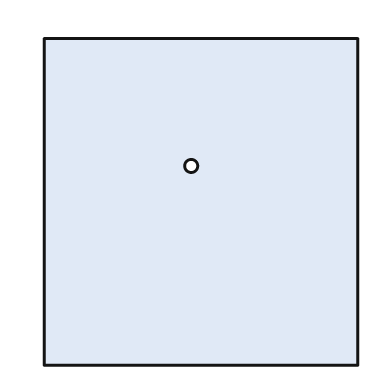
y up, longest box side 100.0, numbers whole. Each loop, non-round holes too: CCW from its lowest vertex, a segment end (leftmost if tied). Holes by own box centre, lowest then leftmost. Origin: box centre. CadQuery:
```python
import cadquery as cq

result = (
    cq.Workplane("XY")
    .moveTo(-48.0, -50.0)
    .lineTo(48.0, -50.0)
    .lineTo(48.0, 50.0)
    .lineTo(-48.0, 50.0)
    .close()
    .moveTo(-3.0, 11.0)
    .circle(2.0)
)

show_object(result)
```